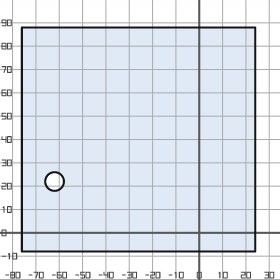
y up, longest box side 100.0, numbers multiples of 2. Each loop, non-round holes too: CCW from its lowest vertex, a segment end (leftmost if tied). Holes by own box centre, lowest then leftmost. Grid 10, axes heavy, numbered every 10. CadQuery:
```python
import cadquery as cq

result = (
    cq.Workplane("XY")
    .moveTo(-76.0, -8.0)
    .lineTo(24.0, -8.0)
    .lineTo(24.0, 88.0)
    .lineTo(-76.0, 88.0)
    .close()
    .moveTo(-62.0, 22.0)
    .circle(4.0)
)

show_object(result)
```